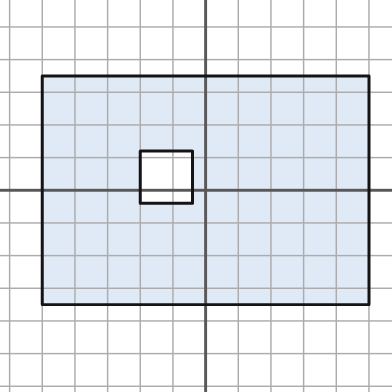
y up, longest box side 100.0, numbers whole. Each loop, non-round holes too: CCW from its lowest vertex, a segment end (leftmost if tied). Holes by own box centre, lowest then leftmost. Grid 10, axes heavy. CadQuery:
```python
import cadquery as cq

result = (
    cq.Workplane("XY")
    .moveTo(-50.0, -35.0)
    .lineTo(50.0, -35.0)
    .lineTo(50.0, 35.0)
    .lineTo(-50.0, 35.0)
    .close()
    .moveTo(-20.0, -4.0)
    .lineTo(-4.0, -4.0)
    .lineTo(-4.0, 12.0)
    .lineTo(-20.0, 12.0)
    .close()
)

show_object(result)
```